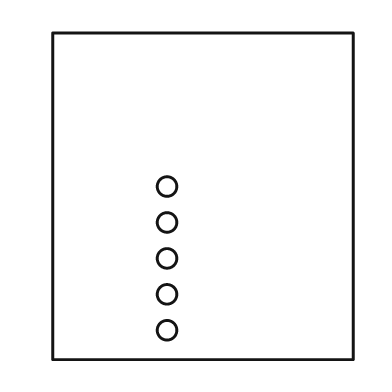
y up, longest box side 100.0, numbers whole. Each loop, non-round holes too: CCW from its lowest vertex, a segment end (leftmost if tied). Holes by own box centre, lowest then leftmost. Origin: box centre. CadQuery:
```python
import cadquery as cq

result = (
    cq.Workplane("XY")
    .moveTo(-46.0, -50.0)
    .lineTo(46.0, -50.0)
    .lineTo(46.0, 50.0)
    .lineTo(-46.0, 50.0)
    .close()
    .moveTo(-11.0, -41.0)
    .circle(3.0)
    .moveTo(-11.0, -30.0)
    .circle(3.0)
    .moveTo(-11.0, -19.0)
    .circle(3.0)
    .moveTo(-11.0, -8.0)
    .circle(3.0)
    .moveTo(-11.0, 3.0)
    .circle(3.0)
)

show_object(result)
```